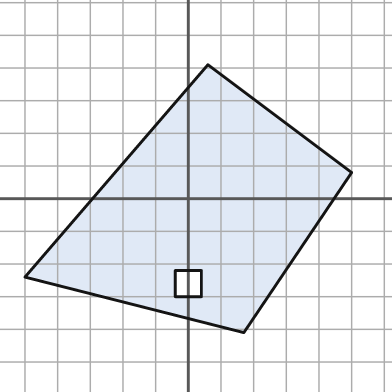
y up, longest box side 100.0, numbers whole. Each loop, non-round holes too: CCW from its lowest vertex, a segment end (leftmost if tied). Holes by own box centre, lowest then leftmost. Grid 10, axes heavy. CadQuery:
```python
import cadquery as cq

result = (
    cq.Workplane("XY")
    .moveTo(17.0, -41.0)
    .lineTo(50.0, 8.0)
    .lineTo(6.0, 41.0)
    .lineTo(-50.0, -24.0)
    .close()
    .moveTo(-4.0, -30.0)
    .lineTo(4.0, -30.0)
    .lineTo(4.0, -22.0)
    .lineTo(-4.0, -22.0)
    .close()
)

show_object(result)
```